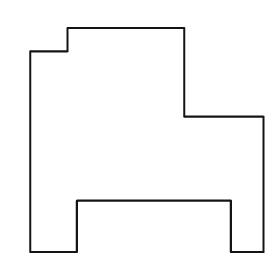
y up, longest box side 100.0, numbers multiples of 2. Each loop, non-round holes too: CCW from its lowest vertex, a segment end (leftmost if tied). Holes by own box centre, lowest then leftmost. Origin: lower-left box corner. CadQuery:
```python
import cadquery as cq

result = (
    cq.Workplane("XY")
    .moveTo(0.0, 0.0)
    .lineTo(20.0, 0.0)
    .lineTo(20.0, 22.0)
    .lineTo(86.0, 22.0)
    .lineTo(86.0, 0.0)
    .lineTo(100.0, 0.0)
    .lineTo(100.0, 58.0)
    .lineTo(66.0, 58.0)
    .lineTo(66.0, 96.0)
    .lineTo(16.0, 96.0)
    .lineTo(16.0, 86.0)
    .lineTo(0.0, 86.0)
    .close()
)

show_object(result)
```